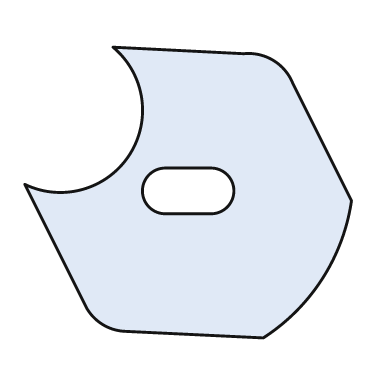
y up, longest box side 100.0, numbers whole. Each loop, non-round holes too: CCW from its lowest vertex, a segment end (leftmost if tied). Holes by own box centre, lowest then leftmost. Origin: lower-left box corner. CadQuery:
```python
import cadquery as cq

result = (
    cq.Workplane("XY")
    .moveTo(73.0, 0.0)
    .threePointArc((91.0, 18.0), (100.0, 42.0))
    .lineTo(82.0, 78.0)
    .threePointArc((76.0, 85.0), (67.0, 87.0))
    .lineTo(27.0, 89.0)
    .threePointArc((32.0, 56.0), (0.0, 47.0))
    .lineTo(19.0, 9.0)
    .threePointArc((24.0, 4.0), (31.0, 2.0))
    .close()
    .moveTo(43.0, 38.0)
    .lineTo(57.0, 38.0)
    .threePointArc((64.0, 45.0), (57.0, 52.0))
    .lineTo(43.0, 52.0)
    .threePointArc((36.0, 45.0), (43.0, 38.0))
    .close()
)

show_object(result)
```